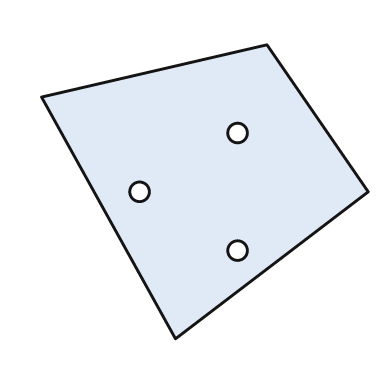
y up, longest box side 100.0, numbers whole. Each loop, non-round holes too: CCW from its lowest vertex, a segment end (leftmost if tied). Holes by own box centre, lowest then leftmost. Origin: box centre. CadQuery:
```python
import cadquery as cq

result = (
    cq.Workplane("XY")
    .moveTo(-9.0, -45.0)
    .lineTo(50.0, 0.0)
    .lineTo(19.0, 45.0)
    .lineTo(-50.0, 29.0)
    .close()
    .moveTo(10.0, -18.0)
    .circle(3.0)
    .moveTo(-20.0, 0.0)
    .circle(3.0)
    .moveTo(10.0, 18.0)
    .circle(3.0)
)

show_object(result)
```